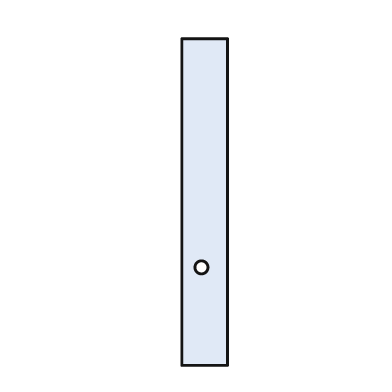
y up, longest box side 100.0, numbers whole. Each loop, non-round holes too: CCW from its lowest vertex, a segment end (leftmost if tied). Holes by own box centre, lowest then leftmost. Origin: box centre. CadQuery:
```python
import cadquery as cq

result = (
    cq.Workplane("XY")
    .moveTo(-7.0, -50.0)
    .lineTo(7.0, -50.0)
    .lineTo(7.0, 50.0)
    .lineTo(-7.0, 50.0)
    .close()
    .moveTo(-1.0, -20.0)
    .circle(2.0)
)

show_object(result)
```